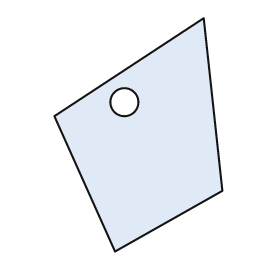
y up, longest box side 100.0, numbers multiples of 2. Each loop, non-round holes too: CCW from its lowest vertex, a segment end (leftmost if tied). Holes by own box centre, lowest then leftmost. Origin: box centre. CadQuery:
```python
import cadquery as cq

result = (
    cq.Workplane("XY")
    .moveTo(-10.0, -50.0)
    .lineTo(36.0, -24.0)
    .lineTo(28.0, 50.0)
    .lineTo(-36.0, 8.0)
    .close()
    .moveTo(-6.0, 14.0)
    .circle(6.0)
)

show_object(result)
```